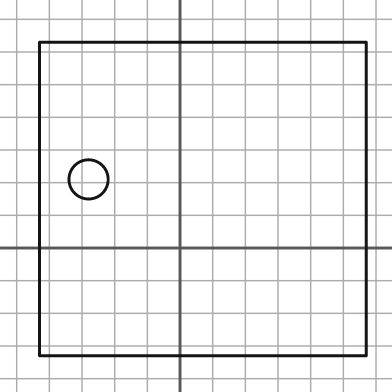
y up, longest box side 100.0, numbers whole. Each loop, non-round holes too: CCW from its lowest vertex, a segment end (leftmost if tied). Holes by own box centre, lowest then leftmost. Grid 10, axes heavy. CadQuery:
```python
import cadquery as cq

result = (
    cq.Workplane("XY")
    .moveTo(-43.0, -33.0)
    .lineTo(57.0, -33.0)
    .lineTo(57.0, 63.0)
    .lineTo(-43.0, 63.0)
    .close()
    .moveTo(-28.0, 21.0)
    .circle(6.0)
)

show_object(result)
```